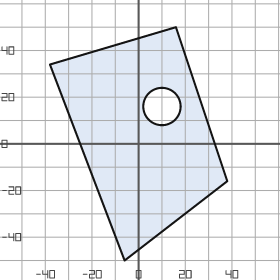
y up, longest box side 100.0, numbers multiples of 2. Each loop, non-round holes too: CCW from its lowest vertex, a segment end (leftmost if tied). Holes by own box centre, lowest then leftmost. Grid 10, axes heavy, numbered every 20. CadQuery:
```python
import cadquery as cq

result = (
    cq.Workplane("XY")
    .moveTo(-6.0, -50.0)
    .lineTo(38.0, -16.0)
    .lineTo(16.0, 50.0)
    .lineTo(-38.0, 34.0)
    .close()
    .moveTo(10.0, 16.0)
    .circle(8.0)
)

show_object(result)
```